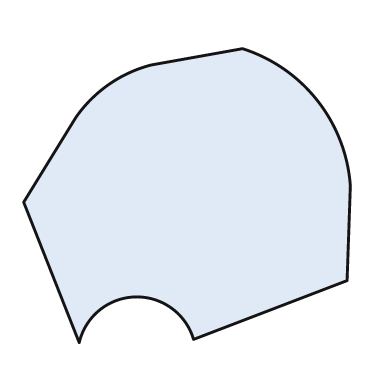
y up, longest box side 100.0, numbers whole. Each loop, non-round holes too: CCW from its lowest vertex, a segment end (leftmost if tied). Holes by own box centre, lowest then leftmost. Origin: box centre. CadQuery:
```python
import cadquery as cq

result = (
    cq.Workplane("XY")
    .moveTo(-33.0, -45.0)
    .threePointArc((-16.0, -31.0), (2.0, -44.0))
    .lineTo(49.0, -26.0)
    .lineTo(50.0, 3.0)
    .threePointArc((40.0, 29.0), (17.0, 45.0))
    .lineTo(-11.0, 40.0)
    .threePointArc((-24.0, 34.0), (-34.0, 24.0))
    .lineTo(-50.0, -2.0)
    .close()
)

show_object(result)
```